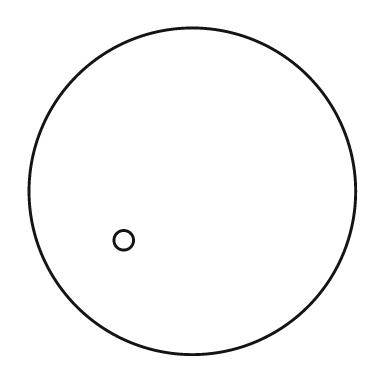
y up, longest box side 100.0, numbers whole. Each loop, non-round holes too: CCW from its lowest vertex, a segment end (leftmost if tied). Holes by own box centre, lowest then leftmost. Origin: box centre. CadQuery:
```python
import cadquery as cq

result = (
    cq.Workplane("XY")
    .moveTo(0.0, 0.0)
    .circle(50.0)
    .moveTo(-21.0, -15.0)
    .circle(3.0)
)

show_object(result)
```